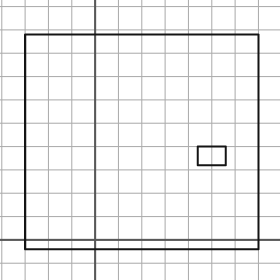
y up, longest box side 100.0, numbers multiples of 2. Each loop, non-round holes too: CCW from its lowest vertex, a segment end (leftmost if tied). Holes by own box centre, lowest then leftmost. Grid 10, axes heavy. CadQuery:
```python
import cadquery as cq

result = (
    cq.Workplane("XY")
    .moveTo(-30.0, -4.0)
    .lineTo(70.0, -4.0)
    .lineTo(70.0, 88.0)
    .lineTo(-30.0, 88.0)
    .close()
    .moveTo(44.0, 32.0)
    .lineTo(56.0, 32.0)
    .lineTo(56.0, 40.0)
    .lineTo(44.0, 40.0)
    .close()
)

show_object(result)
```